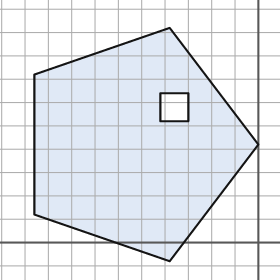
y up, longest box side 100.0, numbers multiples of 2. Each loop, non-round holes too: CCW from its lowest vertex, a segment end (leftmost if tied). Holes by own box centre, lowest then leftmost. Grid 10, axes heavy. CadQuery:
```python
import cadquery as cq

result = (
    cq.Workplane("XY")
    .moveTo(-38.0, -8.0)
    .lineTo(0.0, 42.0)
    .lineTo(-38.0, 92.0)
    .lineTo(-96.0, 72.0)
    .lineTo(-96.0, 12.0)
    .close()
    .moveTo(-42.0, 52.0)
    .lineTo(-30.0, 52.0)
    .lineTo(-30.0, 64.0)
    .lineTo(-42.0, 64.0)
    .close()
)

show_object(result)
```